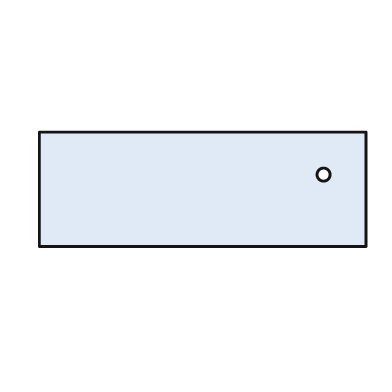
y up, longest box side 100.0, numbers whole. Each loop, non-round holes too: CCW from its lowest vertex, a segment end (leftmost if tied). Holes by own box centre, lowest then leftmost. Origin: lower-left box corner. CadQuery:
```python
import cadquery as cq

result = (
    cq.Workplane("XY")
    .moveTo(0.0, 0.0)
    .lineTo(100.0, 0.0)
    .lineTo(100.0, 35.0)
    .lineTo(0.0, 35.0)
    .close()
    .moveTo(87.0, 22.0)
    .circle(2.0)
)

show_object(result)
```